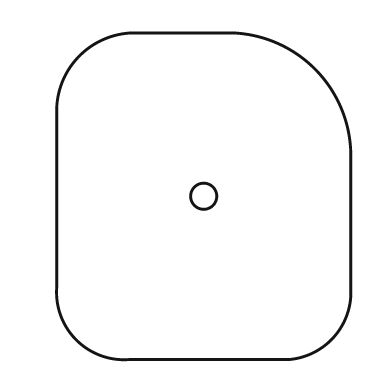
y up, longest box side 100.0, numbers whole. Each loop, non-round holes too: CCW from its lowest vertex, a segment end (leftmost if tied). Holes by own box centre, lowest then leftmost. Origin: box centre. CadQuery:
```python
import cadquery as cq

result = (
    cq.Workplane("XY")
    .moveTo(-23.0, -50.0)
    .lineTo(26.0, -50.0)
    .threePointArc((39.0, -44.0), (45.0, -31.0))
    .lineTo(45.0, 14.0)
    .threePointArc((34.0, 39.0), (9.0, 50.0))
    .lineTo(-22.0, 50.0)
    .threePointArc((-38.0, 43.0), (-45.0, 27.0))
    .lineTo(-45.0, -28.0)
    .threePointArc((-39.0, -44.0), (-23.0, -50.0))
    .close()
    .moveTo(0.0, 0.0)
    .circle(4.0)
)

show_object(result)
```